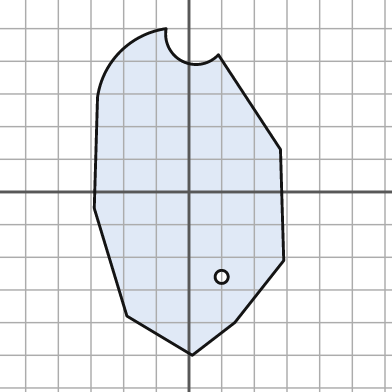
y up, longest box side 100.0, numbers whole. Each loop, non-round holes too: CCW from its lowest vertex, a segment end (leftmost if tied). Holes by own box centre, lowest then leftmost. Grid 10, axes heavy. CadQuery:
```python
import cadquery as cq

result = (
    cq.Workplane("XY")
    .moveTo(1.0, -50.0)
    .lineTo(14.0, -40.0)
    .lineTo(29.0, -21.0)
    .lineTo(28.0, 13.0)
    .lineTo(9.0, 42.0)
    .threePointArc((-2.0, 40.0), (-7.0, 50.0))
    .threePointArc((-21.0, 43.0), (-28.0, 29.0))
    .lineTo(-29.0, -5.0)
    .lineTo(-19.0, -38.0)
    .close()
    .moveTo(10.0, -26.0)
    .circle(2.0)
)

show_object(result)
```